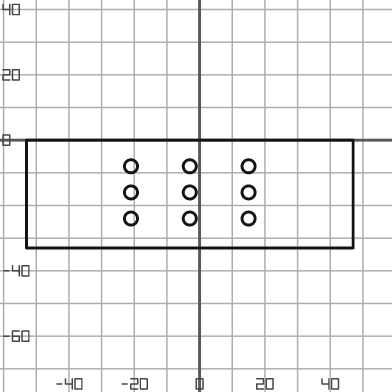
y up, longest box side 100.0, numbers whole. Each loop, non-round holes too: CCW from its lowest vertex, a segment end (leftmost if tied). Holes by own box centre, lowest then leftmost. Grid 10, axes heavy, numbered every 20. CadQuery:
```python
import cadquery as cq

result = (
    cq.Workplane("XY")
    .moveTo(-53.0, -33.0)
    .lineTo(47.0, -33.0)
    .lineTo(47.0, 0.0)
    .lineTo(-53.0, 0.0)
    .close()
    .moveTo(-21.0, -24.0)
    .circle(2.0)
    .moveTo(-3.0, -24.0)
    .circle(2.0)
    .moveTo(15.0, -24.0)
    .circle(2.0)
    .moveTo(-21.0, -16.0)
    .circle(2.0)
    .moveTo(-3.0, -16.0)
    .circle(2.0)
    .moveTo(15.0, -16.0)
    .circle(2.0)
    .moveTo(-21.0, -8.0)
    .circle(2.0)
    .moveTo(-3.0, -8.0)
    .circle(2.0)
    .moveTo(15.0, -8.0)
    .circle(2.0)
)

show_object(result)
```